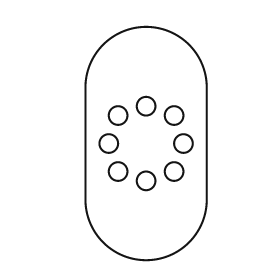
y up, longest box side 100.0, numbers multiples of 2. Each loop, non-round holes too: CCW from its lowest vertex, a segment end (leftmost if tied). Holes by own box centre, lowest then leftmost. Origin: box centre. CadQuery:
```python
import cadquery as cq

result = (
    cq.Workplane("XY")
    .moveTo(-26.0, -24.0)
    .threePointArc((0.0, -50.0), (26.0, -24.0))
    .lineTo(26.0, 24.0)
    .threePointArc((0.0, 50.0), (-26.0, 24.0))
    .close()
    .moveTo(0.0, -16.0)
    .circle(4.0)
    .moveTo(-12.0, -12.0)
    .circle(4.0)
    .moveTo(12.0, -12.0)
    .circle(4.0)
    .moveTo(-16.0, 0.0)
    .circle(4.0)
    .moveTo(16.0, 0.0)
    .circle(4.0)
    .moveTo(-12.0, 12.0)
    .circle(4.0)
    .moveTo(12.0, 12.0)
    .circle(4.0)
    .moveTo(0.0, 16.0)
    .circle(4.0)
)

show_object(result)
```